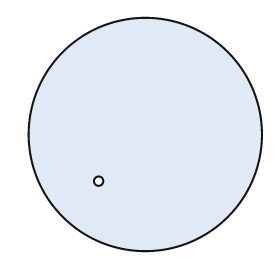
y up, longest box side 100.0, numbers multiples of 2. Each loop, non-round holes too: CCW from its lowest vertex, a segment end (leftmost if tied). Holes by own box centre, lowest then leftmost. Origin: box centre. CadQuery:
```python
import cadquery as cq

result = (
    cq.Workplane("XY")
    .moveTo(0.0, 0.0)
    .circle(50.0)
    .moveTo(-20.0, -20.0)
    .circle(2.0)
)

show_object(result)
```